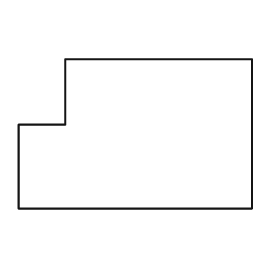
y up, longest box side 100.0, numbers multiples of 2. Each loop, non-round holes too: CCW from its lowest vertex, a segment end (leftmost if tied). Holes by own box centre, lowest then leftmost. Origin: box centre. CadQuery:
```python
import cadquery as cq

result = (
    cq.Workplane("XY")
    .moveTo(-50.0, -32.0)
    .lineTo(50.0, -32.0)
    .lineTo(50.0, 32.0)
    .lineTo(-30.0, 32.0)
    .lineTo(-30.0, 4.0)
    .lineTo(-50.0, 4.0)
    .close()
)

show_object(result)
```